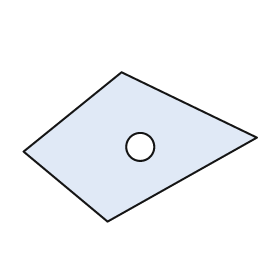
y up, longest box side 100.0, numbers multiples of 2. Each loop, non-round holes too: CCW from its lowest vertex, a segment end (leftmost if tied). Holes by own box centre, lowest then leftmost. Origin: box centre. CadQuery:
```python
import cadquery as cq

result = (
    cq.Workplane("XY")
    .moveTo(-14.0, -32.0)
    .lineTo(50.0, 4.0)
    .lineTo(-8.0, 32.0)
    .lineTo(-50.0, -2.0)
    .close()
    .moveTo(0.0, 0.0)
    .circle(6.0)
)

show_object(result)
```